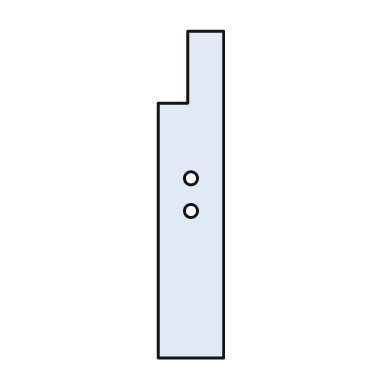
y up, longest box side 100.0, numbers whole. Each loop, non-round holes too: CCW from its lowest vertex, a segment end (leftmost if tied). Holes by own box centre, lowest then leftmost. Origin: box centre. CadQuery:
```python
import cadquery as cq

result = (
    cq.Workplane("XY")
    .moveTo(-10.0, -50.0)
    .lineTo(10.0, -50.0)
    .lineTo(10.0, 50.0)
    .lineTo(-1.0, 50.0)
    .lineTo(-1.0, 28.0)
    .lineTo(-10.0, 28.0)
    .close()
    .moveTo(0.0, -5.0)
    .circle(2.0)
    .moveTo(0.0, 5.0)
    .circle(2.0)
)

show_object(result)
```